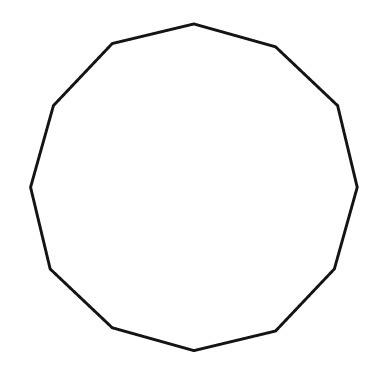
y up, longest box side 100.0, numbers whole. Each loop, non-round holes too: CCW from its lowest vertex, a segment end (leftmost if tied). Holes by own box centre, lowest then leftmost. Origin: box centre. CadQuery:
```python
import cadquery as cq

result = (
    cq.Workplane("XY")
    .moveTo(0.0, -50.0)
    .lineTo(25.0, -44.0)
    .lineTo(43.0, -25.0)
    .lineTo(50.0, 0.0)
    .lineTo(44.0, 25.0)
    .lineTo(25.0, 43.0)
    .lineTo(0.0, 50.0)
    .lineTo(-25.0, 44.0)
    .lineTo(-43.0, 25.0)
    .lineTo(-50.0, 0.0)
    .lineTo(-44.0, -25.0)
    .lineTo(-25.0, -43.0)
    .close()
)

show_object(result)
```